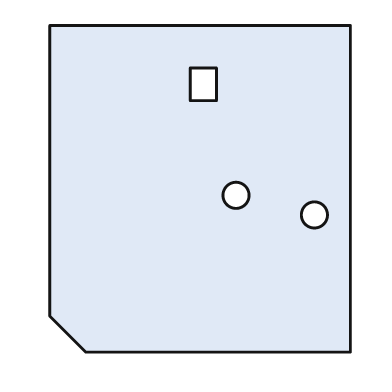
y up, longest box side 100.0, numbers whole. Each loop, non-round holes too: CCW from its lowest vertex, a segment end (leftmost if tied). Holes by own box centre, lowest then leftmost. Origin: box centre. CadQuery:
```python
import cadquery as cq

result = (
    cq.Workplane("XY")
    .moveTo(-35.0, -50.0)
    .lineTo(46.0, -50.0)
    .lineTo(46.0, 50.0)
    .lineTo(-46.0, 50.0)
    .lineTo(-46.0, -39.0)
    .close()
    .moveTo(35.0, -8.0)
    .circle(4.0)
    .moveTo(11.0, -2.0)
    .circle(4.0)
    .moveTo(-3.0, 27.0)
    .lineTo(5.0, 27.0)
    .lineTo(5.0, 37.0)
    .lineTo(-3.0, 37.0)
    .close()
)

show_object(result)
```